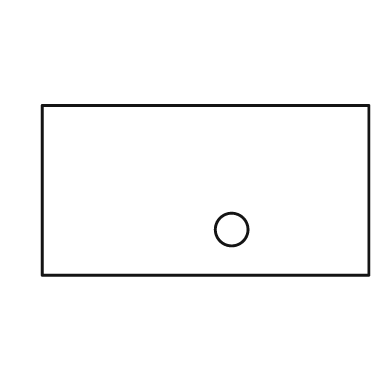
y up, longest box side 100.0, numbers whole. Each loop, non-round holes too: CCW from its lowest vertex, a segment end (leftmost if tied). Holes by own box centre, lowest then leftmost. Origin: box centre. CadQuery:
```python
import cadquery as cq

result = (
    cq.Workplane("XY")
    .moveTo(-50.0, -26.0)
    .lineTo(50.0, -26.0)
    .lineTo(50.0, 26.0)
    .lineTo(-50.0, 26.0)
    .close()
    .moveTo(8.0, -12.0)
    .circle(5.0)
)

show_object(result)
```